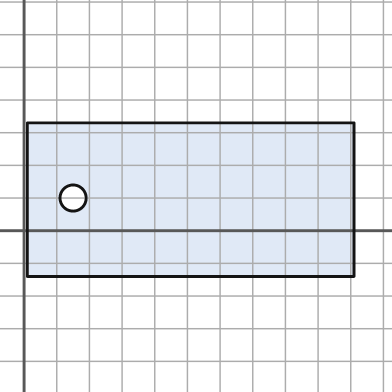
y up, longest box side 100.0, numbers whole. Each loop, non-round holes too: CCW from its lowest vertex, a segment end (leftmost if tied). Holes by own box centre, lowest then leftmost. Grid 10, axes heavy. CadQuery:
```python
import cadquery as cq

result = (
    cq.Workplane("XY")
    .moveTo(1.0, -14.0)
    .lineTo(101.0, -14.0)
    .lineTo(101.0, 33.0)
    .lineTo(1.0, 33.0)
    .close()
    .moveTo(15.0, 10.0)
    .circle(4.0)
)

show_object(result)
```